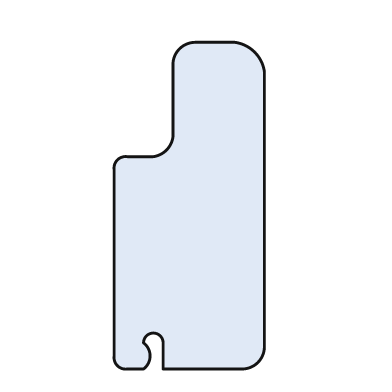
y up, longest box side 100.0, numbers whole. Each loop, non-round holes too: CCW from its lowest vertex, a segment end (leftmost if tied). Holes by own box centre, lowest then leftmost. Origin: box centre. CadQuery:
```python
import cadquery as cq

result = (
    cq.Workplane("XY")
    .moveTo(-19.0, -50.0)
    .lineTo(-14.0, -50.0)
    .threePointArc((-12.0, -46.0), (-14.0, -42.0))
    .threePointArc((-11.0, -39.0), (-8.0, -42.0))
    .lineTo(-8.0, -50.0)
    .lineTo(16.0, -50.0)
    .threePointArc((21.0, -48.0), (23.0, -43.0))
    .lineTo(23.0, 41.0)
    .threePointArc((20.0, 47.0), (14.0, 50.0))
    .lineTo(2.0, 50.0)
    .threePointArc((-3.0, 48.0), (-5.0, 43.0))
    .lineTo(-5.0, 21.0)
    .threePointArc((-7.0, 17.0), (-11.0, 15.0))
    .lineTo(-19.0, 15.0)
    .threePointArc((-22.0, 14.0), (-23.0, 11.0))
    .lineTo(-23.0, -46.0)
    .threePointArc((-22.0, -49.0), (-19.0, -50.0))
    .close()
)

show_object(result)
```